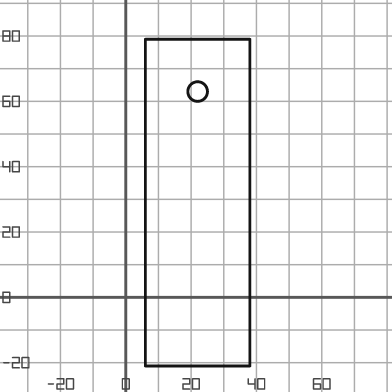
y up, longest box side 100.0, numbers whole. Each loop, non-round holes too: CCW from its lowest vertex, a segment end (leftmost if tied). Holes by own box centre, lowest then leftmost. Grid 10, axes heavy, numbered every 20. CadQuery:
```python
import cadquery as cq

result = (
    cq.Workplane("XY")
    .moveTo(6.0, -21.0)
    .lineTo(38.0, -21.0)
    .lineTo(38.0, 79.0)
    .lineTo(6.0, 79.0)
    .close()
    .moveTo(22.0, 63.0)
    .circle(3.0)
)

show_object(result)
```